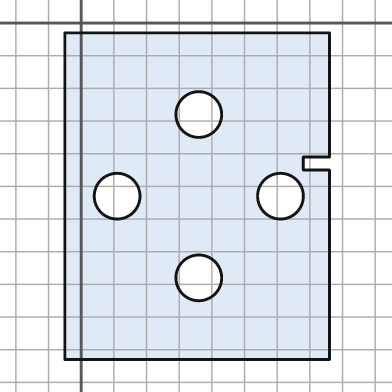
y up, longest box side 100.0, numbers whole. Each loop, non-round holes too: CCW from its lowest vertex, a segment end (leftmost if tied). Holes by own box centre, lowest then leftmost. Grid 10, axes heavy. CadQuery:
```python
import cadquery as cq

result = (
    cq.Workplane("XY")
    .moveTo(-5.0, -103.0)
    .lineTo(76.0, -103.0)
    .lineTo(76.0, -45.0)
    .lineTo(68.0, -45.0)
    .lineTo(68.0, -41.0)
    .lineTo(76.0, -41.0)
    .lineTo(76.0, -3.0)
    .lineTo(-5.0, -3.0)
    .close()
    .moveTo(36.0, -78.0)
    .circle(7.0)
    .moveTo(11.0, -53.0)
    .circle(7.0)
    .moveTo(61.0, -53.0)
    .circle(7.0)
    .moveTo(36.0, -28.0)
    .circle(7.0)
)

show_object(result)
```